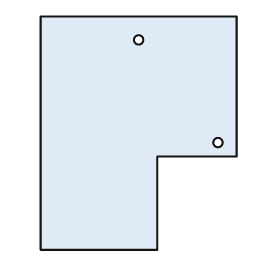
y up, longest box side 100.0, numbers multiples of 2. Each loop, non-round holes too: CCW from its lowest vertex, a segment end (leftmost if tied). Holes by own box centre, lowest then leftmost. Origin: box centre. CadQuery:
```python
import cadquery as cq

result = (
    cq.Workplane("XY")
    .moveTo(-42.0, -50.0)
    .lineTo(8.0, -50.0)
    .lineTo(8.0, -10.0)
    .lineTo(42.0, -10.0)
    .lineTo(42.0, 50.0)
    .lineTo(-42.0, 50.0)
    .close()
    .moveTo(34.0, -4.0)
    .circle(2.0)
    .moveTo(0.0, 40.0)
    .circle(2.0)
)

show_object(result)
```